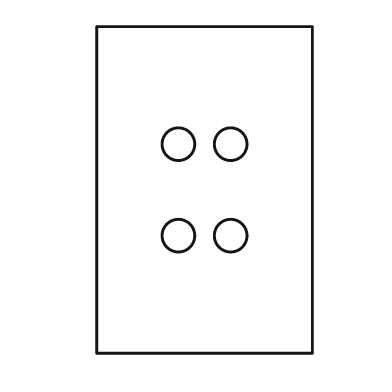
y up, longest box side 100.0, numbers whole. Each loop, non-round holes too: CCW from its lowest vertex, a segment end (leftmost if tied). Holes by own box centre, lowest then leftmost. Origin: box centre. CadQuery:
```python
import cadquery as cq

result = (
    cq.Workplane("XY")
    .moveTo(-33.0, -50.0)
    .lineTo(33.0, -50.0)
    .lineTo(33.0, 50.0)
    .lineTo(-33.0, 50.0)
    .close()
    .moveTo(-8.0, -14.0)
    .circle(5.0)
    .moveTo(8.0, -14.0)
    .circle(5.0)
    .moveTo(-8.0, 14.0)
    .circle(5.0)
    .moveTo(8.0, 14.0)
    .circle(5.0)
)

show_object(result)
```